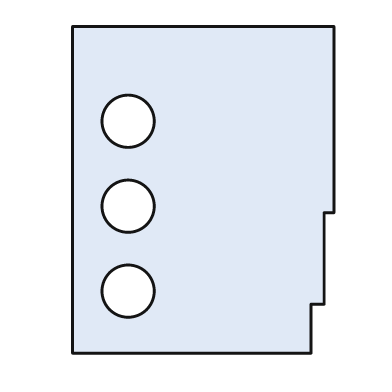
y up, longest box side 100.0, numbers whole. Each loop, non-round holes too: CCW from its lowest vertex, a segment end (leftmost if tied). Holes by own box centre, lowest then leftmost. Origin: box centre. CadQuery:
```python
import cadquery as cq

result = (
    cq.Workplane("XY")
    .moveTo(-40.0, -50.0)
    .lineTo(33.0, -50.0)
    .lineTo(33.0, -35.0)
    .lineTo(37.0, -35.0)
    .lineTo(37.0, -7.0)
    .lineTo(40.0, -7.0)
    .lineTo(40.0, 50.0)
    .lineTo(-40.0, 50.0)
    .close()
    .moveTo(-23.0, -31.0)
    .circle(8.0)
    .moveTo(-23.0, -5.0)
    .circle(8.0)
    .moveTo(-23.0, 21.0)
    .circle(8.0)
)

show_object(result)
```